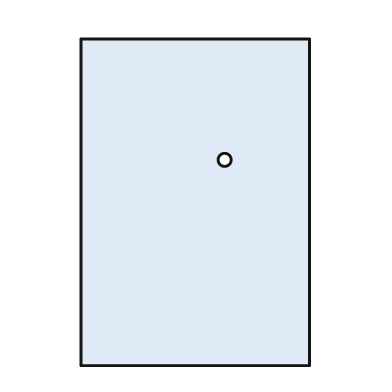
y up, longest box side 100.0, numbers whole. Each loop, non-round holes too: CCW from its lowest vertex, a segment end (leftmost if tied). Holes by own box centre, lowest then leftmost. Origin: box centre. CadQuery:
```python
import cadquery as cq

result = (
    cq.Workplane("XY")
    .moveTo(-35.0, -50.0)
    .lineTo(35.0, -50.0)
    .lineTo(35.0, 50.0)
    .lineTo(-35.0, 50.0)
    .close()
    .moveTo(9.0, 13.0)
    .circle(2.0)
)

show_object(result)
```